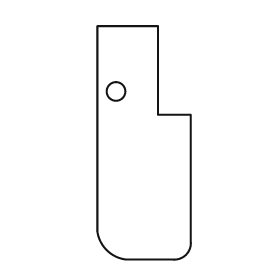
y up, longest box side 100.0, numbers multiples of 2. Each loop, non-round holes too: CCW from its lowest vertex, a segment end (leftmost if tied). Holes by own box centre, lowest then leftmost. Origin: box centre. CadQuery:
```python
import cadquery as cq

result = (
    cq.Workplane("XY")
    .moveTo(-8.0, -50.0)
    .lineTo(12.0, -50.0)
    .threePointArc((18.0, -48.0), (20.0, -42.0))
    .lineTo(20.0, 12.0)
    .lineTo(6.0, 12.0)
    .lineTo(6.0, 50.0)
    .lineTo(-20.0, 50.0)
    .lineTo(-20.0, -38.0)
    .threePointArc((-16.0, -46.0), (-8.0, -50.0))
    .close()
    .moveTo(-12.0, 22.0)
    .circle(4.0)
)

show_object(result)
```